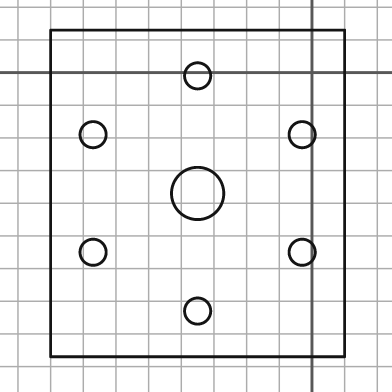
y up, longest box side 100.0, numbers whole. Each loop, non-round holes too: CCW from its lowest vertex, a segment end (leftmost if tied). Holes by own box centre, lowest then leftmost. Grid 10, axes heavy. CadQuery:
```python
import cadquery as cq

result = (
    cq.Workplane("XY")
    .moveTo(-80.0, -87.0)
    .lineTo(10.0, -87.0)
    .lineTo(10.0, 13.0)
    .lineTo(-80.0, 13.0)
    .close()
    .moveTo(-35.0, -73.0)
    .circle(4.0)
    .moveTo(-67.0, -55.0)
    .circle(4.0)
    .moveTo(-3.0, -55.0)
    .circle(4.0)
    .moveTo(-35.0, -37.0)
    .circle(8.0)
    .moveTo(-67.0, -19.0)
    .circle(4.0)
    .moveTo(-3.0, -19.0)
    .circle(4.0)
    .moveTo(-35.0, -1.0)
    .circle(4.0)
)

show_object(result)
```